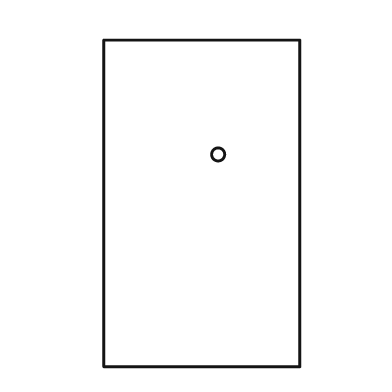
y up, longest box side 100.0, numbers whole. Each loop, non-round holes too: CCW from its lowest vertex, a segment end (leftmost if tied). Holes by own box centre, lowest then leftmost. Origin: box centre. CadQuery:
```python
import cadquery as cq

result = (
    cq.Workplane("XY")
    .moveTo(-30.0, -50.0)
    .lineTo(30.0, -50.0)
    .lineTo(30.0, 50.0)
    .lineTo(-30.0, 50.0)
    .close()
    .moveTo(5.0, 15.0)
    .circle(2.0)
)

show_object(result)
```